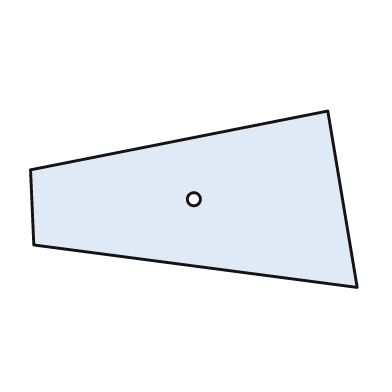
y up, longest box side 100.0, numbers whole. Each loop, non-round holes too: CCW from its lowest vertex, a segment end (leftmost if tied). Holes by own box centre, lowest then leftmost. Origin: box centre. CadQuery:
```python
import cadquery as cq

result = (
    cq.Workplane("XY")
    .moveTo(50.0, -27.0)
    .lineTo(41.0, 27.0)
    .lineTo(-50.0, 9.0)
    .lineTo(-49.0, -14.0)
    .close()
    .moveTo(0.0, 0.0)
    .circle(2.0)
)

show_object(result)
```